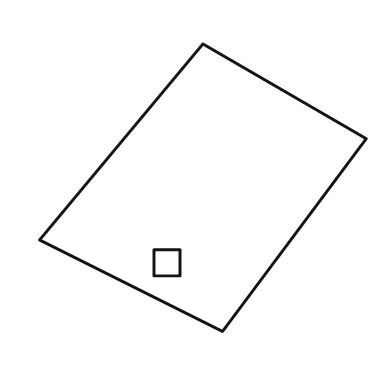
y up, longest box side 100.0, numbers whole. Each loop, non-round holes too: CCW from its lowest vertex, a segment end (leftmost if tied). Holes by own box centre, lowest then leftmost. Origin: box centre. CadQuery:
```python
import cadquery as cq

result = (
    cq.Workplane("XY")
    .moveTo(6.0, -44.0)
    .lineTo(50.0, 15.0)
    .lineTo(0.0, 44.0)
    .lineTo(-50.0, -16.0)
    .close()
    .moveTo(-15.0, -27.0)
    .lineTo(-7.0, -27.0)
    .lineTo(-7.0, -19.0)
    .lineTo(-15.0, -19.0)
    .close()
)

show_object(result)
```